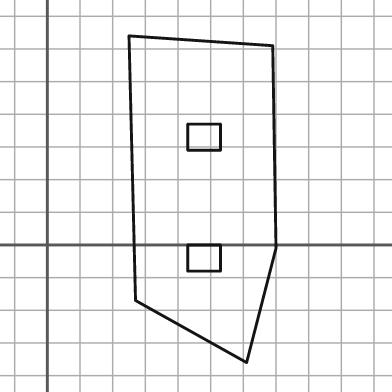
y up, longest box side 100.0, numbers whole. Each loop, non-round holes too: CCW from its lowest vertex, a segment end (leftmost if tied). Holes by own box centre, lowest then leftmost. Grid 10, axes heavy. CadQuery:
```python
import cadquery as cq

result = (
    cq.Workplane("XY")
    .moveTo(61.0, -36.0)
    .lineTo(70.0, -1.0)
    .lineTo(69.0, 61.0)
    .lineTo(25.0, 64.0)
    .lineTo(27.0, -17.0)
    .close()
    .moveTo(43.0, -8.0)
    .lineTo(53.0, -8.0)
    .lineTo(53.0, 0.0)
    .lineTo(43.0, 0.0)
    .close()
    .moveTo(43.0, 29.0)
    .lineTo(53.0, 29.0)
    .lineTo(53.0, 37.0)
    .lineTo(43.0, 37.0)
    .close()
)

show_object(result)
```